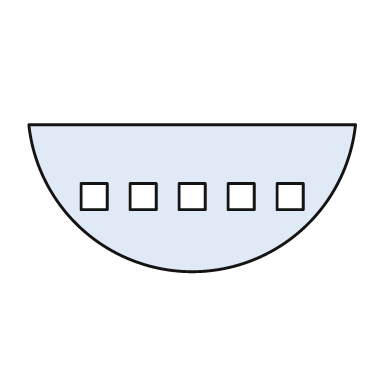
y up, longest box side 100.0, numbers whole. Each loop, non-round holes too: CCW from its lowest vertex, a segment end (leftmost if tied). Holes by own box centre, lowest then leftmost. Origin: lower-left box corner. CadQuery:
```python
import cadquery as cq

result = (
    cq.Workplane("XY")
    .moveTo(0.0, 45.0)
    .threePointArc((50.0, 0.0), (100.0, 45.0))
    .close()
    .moveTo(16.0, 19.0)
    .lineTo(24.0, 19.0)
    .lineTo(24.0, 27.0)
    .lineTo(16.0, 27.0)
    .close()
    .moveTo(31.0, 19.0)
    .lineTo(39.0, 19.0)
    .lineTo(39.0, 27.0)
    .lineTo(31.0, 27.0)
    .close()
    .moveTo(46.0, 19.0)
    .lineTo(54.0, 19.0)
    .lineTo(54.0, 27.0)
    .lineTo(46.0, 27.0)
    .close()
    .moveTo(61.0, 19.0)
    .lineTo(69.0, 19.0)
    .lineTo(69.0, 27.0)
    .lineTo(61.0, 27.0)
    .close()
    .moveTo(76.0, 19.0)
    .lineTo(84.0, 19.0)
    .lineTo(84.0, 27.0)
    .lineTo(76.0, 27.0)
    .close()
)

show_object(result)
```